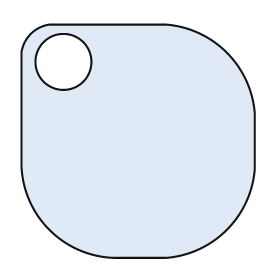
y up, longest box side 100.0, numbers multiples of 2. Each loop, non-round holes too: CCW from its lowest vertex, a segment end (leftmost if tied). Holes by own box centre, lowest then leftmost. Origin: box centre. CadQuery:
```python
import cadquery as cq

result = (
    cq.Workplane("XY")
    .moveTo(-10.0, -50.0)
    .lineTo(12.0, -50.0)
    .threePointArc((38.0, -38.0), (50.0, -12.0))
    .lineTo(50.0, 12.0)
    .threePointArc((38.0, 38.0), (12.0, 50.0))
    .lineTo(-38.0, 50.0)
    .threePointArc((-46.0, 46.0), (-50.0, 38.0))
    .lineTo(-50.0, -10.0)
    .threePointArc((-38.0, -38.0), (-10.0, -50.0))
    .close()
    .moveTo(-32.0, 34.0)
    .circle(12.0)
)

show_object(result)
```